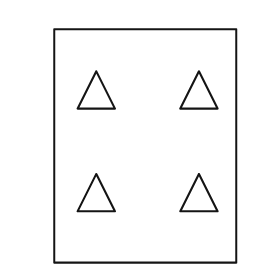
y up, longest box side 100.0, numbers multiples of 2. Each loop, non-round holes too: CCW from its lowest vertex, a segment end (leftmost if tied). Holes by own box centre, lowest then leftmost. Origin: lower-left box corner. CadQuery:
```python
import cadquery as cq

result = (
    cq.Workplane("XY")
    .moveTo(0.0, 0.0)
    .lineTo(78.0, 0.0)
    .lineTo(78.0, 100.0)
    .lineTo(0.0, 100.0)
    .close()
    .moveTo(10.0, 22.0)
    .lineTo(26.0, 22.0)
    .lineTo(18.0, 38.0)
    .close()
    .moveTo(54.0, 22.0)
    .lineTo(70.0, 22.0)
    .lineTo(62.0, 38.0)
    .close()
    .moveTo(10.0, 66.0)
    .lineTo(26.0, 66.0)
    .lineTo(18.0, 82.0)
    .close()
    .moveTo(54.0, 66.0)
    .lineTo(70.0, 66.0)
    .lineTo(62.0, 82.0)
    .close()
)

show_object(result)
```